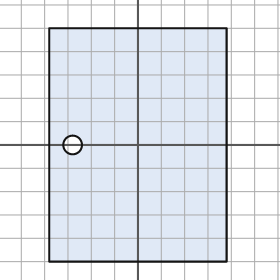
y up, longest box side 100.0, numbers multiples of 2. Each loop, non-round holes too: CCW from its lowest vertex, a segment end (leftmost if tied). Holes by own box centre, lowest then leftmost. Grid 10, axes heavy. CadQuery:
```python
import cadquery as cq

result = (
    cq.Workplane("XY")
    .moveTo(-38.0, -50.0)
    .lineTo(38.0, -50.0)
    .lineTo(38.0, 50.0)
    .lineTo(-38.0, 50.0)
    .close()
    .moveTo(-28.0, 0.0)
    .circle(4.0)
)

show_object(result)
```